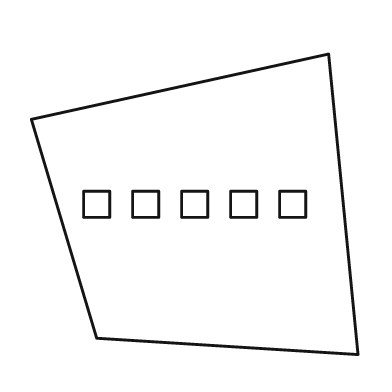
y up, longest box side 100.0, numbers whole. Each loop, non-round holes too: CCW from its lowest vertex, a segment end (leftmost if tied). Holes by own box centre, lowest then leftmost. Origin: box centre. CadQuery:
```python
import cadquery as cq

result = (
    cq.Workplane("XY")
    .moveTo(50.0, -46.0)
    .lineTo(41.0, 46.0)
    .lineTo(-50.0, 26.0)
    .lineTo(-30.0, -41.0)
    .close()
    .moveTo(-34.0, -4.0)
    .lineTo(-26.0, -4.0)
    .lineTo(-26.0, 4.0)
    .lineTo(-34.0, 4.0)
    .close()
    .moveTo(-19.0, -4.0)
    .lineTo(-11.0, -4.0)
    .lineTo(-11.0, 4.0)
    .lineTo(-19.0, 4.0)
    .close()
    .moveTo(-4.0, -4.0)
    .lineTo(4.0, -4.0)
    .lineTo(4.0, 4.0)
    .lineTo(-4.0, 4.0)
    .close()
    .moveTo(11.0, -4.0)
    .lineTo(19.0, -4.0)
    .lineTo(19.0, 4.0)
    .lineTo(11.0, 4.0)
    .close()
    .moveTo(26.0, -4.0)
    .lineTo(34.0, -4.0)
    .lineTo(34.0, 4.0)
    .lineTo(26.0, 4.0)
    .close()
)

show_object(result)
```